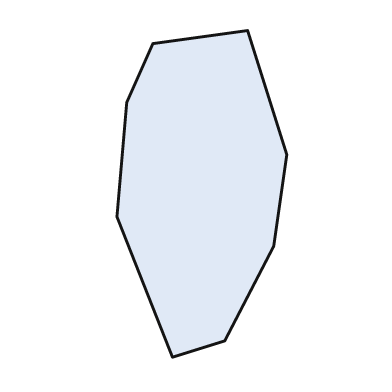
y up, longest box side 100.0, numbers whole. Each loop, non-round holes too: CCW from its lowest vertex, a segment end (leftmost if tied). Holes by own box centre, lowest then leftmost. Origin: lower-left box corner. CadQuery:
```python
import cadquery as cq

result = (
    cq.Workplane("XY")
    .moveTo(17.0, 0.0)
    .lineTo(33.0, 5.0)
    .lineTo(48.0, 34.0)
    .lineTo(52.0, 62.0)
    .lineTo(40.0, 100.0)
    .lineTo(11.0, 96.0)
    .lineTo(3.0, 78.0)
    .lineTo(0.0, 43.0)
    .close()
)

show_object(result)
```